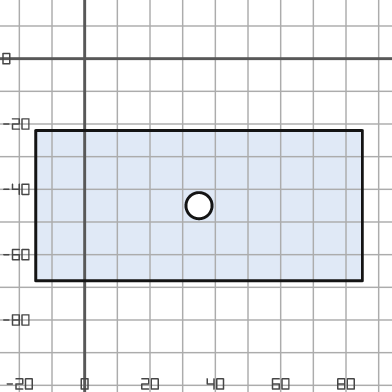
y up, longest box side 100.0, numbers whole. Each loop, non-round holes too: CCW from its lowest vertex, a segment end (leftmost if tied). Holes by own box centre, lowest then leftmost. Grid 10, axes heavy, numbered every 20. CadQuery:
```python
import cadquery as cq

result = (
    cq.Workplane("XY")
    .moveTo(-15.0, -68.0)
    .lineTo(85.0, -68.0)
    .lineTo(85.0, -22.0)
    .lineTo(-15.0, -22.0)
    .close()
    .moveTo(35.0, -45.0)
    .circle(4.0)
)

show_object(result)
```